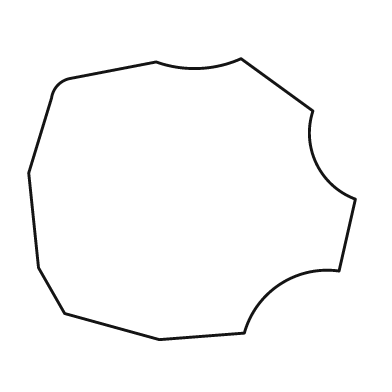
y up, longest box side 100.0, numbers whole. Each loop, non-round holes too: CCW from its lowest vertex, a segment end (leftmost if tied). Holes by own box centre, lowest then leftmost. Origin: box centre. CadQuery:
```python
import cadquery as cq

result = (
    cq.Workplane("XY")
    .moveTo(-10.0, -43.0)
    .lineTo(16.0, -41.0)
    .threePointArc((27.0, -26.0), (45.0, -22.0))
    .lineTo(50.0, 0.0)
    .threePointArc((38.0, 11.0), (37.0, 27.0))
    .lineTo(15.0, 43.0)
    .threePointArc((2.0, 40.0), (-11.0, 42.0))
    .lineTo(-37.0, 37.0)
    .threePointArc((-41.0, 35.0), (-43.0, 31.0))
    .lineTo(-50.0, 8.0)
    .lineTo(-47.0, -21.0)
    .lineTo(-39.0, -35.0)
    .close()
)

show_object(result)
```